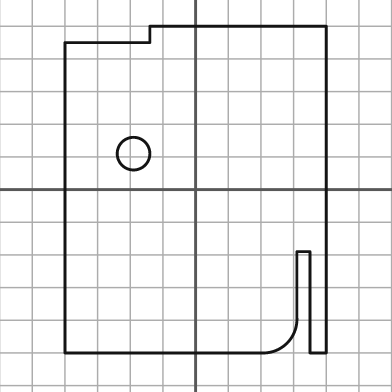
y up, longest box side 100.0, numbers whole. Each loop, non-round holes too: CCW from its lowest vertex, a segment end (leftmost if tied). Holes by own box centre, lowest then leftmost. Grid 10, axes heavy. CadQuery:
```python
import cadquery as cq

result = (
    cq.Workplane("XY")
    .moveTo(-40.0, -50.0)
    .lineTo(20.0, -50.0)
    .threePointArc((28.0, -47.0), (31.0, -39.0))
    .lineTo(31.0, -19.0)
    .lineTo(35.0, -19.0)
    .lineTo(35.0, -50.0)
    .lineTo(40.0, -50.0)
    .lineTo(40.0, 50.0)
    .lineTo(-14.0, 50.0)
    .lineTo(-14.0, 45.0)
    .lineTo(-40.0, 45.0)
    .close()
    .moveTo(-19.0, 11.0)
    .circle(5.0)
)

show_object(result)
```